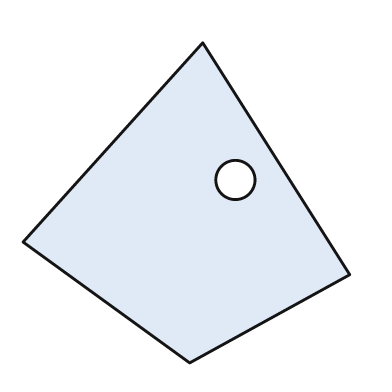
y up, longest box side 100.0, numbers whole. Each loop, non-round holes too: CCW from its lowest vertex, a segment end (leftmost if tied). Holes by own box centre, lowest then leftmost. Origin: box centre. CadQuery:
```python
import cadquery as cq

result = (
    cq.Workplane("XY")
    .moveTo(1.0, -49.0)
    .lineTo(50.0, -22.0)
    .lineTo(5.0, 49.0)
    .lineTo(-50.0, -12.0)
    .close()
    .moveTo(15.0, 7.0)
    .circle(6.0)
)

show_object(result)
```